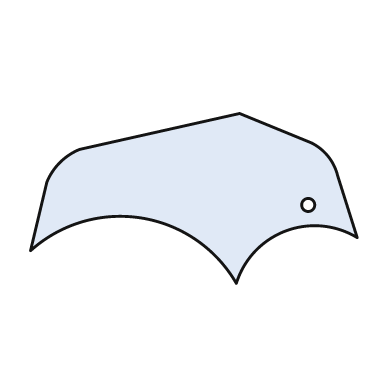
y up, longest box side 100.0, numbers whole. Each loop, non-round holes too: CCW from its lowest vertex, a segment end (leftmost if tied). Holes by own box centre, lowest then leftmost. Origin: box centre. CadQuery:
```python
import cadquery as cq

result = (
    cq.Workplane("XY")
    .moveTo(13.0, -26.0)
    .threePointArc((28.0, -10.0), (50.0, -12.0))
    .lineTo(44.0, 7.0)
    .threePointArc((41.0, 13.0), (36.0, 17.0))
    .lineTo(14.0, 26.0)
    .lineTo(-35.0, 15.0)
    .threePointArc((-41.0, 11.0), (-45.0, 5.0))
    .lineTo(-50.0, -16.0)
    .threePointArc((-16.0, -6.0), (13.0, -26.0))
    .close()
    .moveTo(35.0, -2.0)
    .circle(2.0)
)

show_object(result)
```